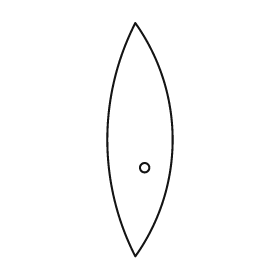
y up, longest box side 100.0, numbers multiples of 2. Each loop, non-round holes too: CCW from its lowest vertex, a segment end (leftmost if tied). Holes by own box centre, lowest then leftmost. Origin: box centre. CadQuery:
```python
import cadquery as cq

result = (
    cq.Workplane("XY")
    .moveTo(-2.0, -50.0)
    .threePointArc((14.0, 0.0), (-2.0, 50.0))
    .threePointArc((-14.0, 0.0), (-2.0, -50.0))
    .close()
    .moveTo(2.0, -12.0)
    .circle(2.0)
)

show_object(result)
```